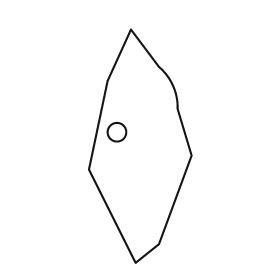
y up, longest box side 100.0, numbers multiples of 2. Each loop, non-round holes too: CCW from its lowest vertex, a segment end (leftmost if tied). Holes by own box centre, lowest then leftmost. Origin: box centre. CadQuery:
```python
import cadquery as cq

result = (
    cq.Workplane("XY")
    .moveTo(-2.0, -50.0)
    .lineTo(8.0, -42.0)
    .lineTo(22.0, -4.0)
    .lineTo(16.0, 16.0)
    .threePointArc((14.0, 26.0), (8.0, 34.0))
    .lineTo(-4.0, 50.0)
    .lineTo(-14.0, 28.0)
    .lineTo(-22.0, -10.0)
    .close()
    .moveTo(-10.0, 6.0)
    .circle(4.0)
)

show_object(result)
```